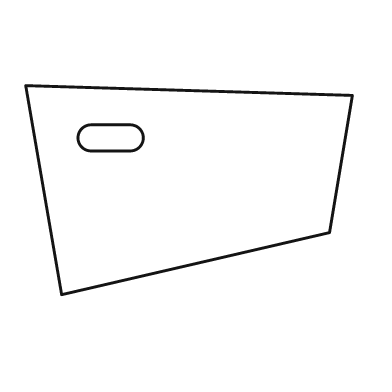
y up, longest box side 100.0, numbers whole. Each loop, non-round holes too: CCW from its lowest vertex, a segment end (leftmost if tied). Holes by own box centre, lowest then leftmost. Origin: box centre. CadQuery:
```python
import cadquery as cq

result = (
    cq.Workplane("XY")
    .moveTo(-39.0, -32.0)
    .lineTo(43.0, -13.0)
    .lineTo(50.0, 29.0)
    .lineTo(-50.0, 32.0)
    .close()
    .moveTo(-30.0, 12.0)
    .lineTo(-18.0, 12.0)
    .threePointArc((-14.0, 16.0), (-18.0, 20.0))
    .lineTo(-30.0, 20.0)
    .threePointArc((-34.0, 16.0), (-30.0, 12.0))
    .close()
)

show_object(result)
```